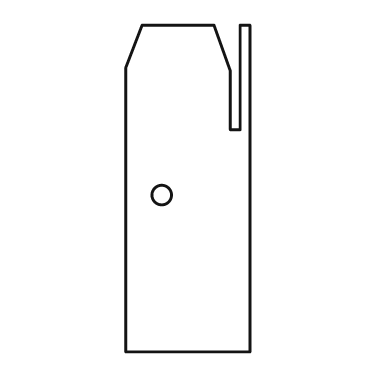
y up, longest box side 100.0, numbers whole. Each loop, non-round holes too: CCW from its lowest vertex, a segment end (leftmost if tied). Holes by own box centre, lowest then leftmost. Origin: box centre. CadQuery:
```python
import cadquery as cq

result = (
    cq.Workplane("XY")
    .moveTo(-19.0, -50.0)
    .lineTo(19.0, -50.0)
    .lineTo(19.0, 50.0)
    .lineTo(16.0, 50.0)
    .lineTo(16.0, 18.0)
    .lineTo(13.0, 18.0)
    .lineTo(13.0, 36.0)
    .lineTo(8.0, 50.0)
    .lineTo(-14.0, 50.0)
    .lineTo(-19.0, 37.0)
    .close()
    .moveTo(-8.0, -2.0)
    .circle(3.0)
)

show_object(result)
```